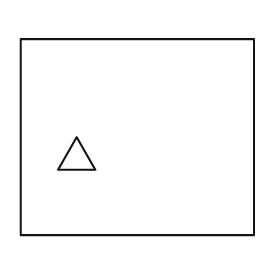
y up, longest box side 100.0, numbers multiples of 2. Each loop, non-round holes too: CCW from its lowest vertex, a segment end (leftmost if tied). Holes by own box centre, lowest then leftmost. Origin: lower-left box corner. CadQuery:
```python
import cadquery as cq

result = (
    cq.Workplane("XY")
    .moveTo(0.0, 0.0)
    .lineTo(100.0, 0.0)
    .lineTo(100.0, 84.0)
    .lineTo(0.0, 84.0)
    .close()
    .moveTo(16.0, 28.0)
    .lineTo(32.0, 28.0)
    .lineTo(24.0, 42.0)
    .close()
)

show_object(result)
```